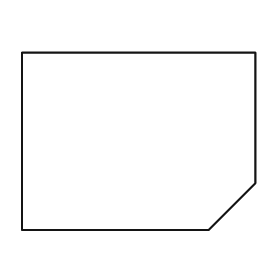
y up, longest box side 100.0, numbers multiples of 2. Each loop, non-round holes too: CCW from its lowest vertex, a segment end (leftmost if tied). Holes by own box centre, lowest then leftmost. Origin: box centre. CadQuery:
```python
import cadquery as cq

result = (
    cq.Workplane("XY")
    .moveTo(-50.0, -38.0)
    .lineTo(30.0, -38.0)
    .lineTo(50.0, -18.0)
    .lineTo(50.0, 38.0)
    .lineTo(-50.0, 38.0)
    .close()
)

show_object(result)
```